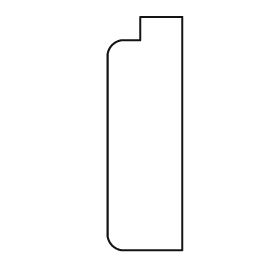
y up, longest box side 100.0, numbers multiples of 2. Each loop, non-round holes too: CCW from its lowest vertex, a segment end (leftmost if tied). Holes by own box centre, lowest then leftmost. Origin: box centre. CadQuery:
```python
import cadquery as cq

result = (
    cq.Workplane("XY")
    .moveTo(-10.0, -50.0)
    .lineTo(16.0, -50.0)
    .lineTo(16.0, 50.0)
    .lineTo(-2.0, 50.0)
    .lineTo(-2.0, 40.0)
    .lineTo(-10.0, 40.0)
    .threePointArc((-14.0, 38.0), (-16.0, 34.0))
    .lineTo(-16.0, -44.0)
    .threePointArc((-14.0, -48.0), (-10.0, -50.0))
    .close()
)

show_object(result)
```